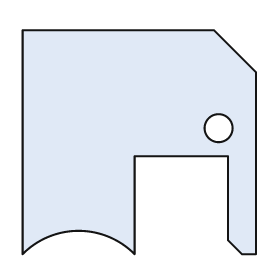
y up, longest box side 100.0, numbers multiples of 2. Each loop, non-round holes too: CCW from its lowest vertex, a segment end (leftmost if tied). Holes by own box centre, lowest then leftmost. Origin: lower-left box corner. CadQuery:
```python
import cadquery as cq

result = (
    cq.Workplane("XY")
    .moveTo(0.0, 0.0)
    .threePointArc((24.0, 10.0), (48.0, 0.0))
    .lineTo(48.0, 42.0)
    .lineTo(88.0, 42.0)
    .lineTo(88.0, 6.0)
    .lineTo(94.0, 0.0)
    .lineTo(100.0, 0.0)
    .lineTo(100.0, 78.0)
    .lineTo(82.0, 96.0)
    .lineTo(0.0, 96.0)
    .close()
    .moveTo(84.0, 54.0)
    .circle(6.0)
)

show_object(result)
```